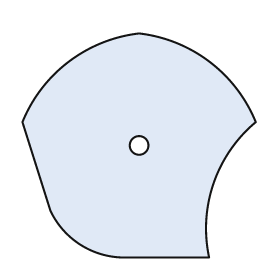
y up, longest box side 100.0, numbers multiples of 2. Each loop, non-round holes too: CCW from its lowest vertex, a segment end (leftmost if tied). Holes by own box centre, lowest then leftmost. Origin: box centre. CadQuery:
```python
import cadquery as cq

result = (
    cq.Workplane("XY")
    .moveTo(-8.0, -48.0)
    .lineTo(30.0, -48.0)
    .threePointArc((32.0, -16.0), (50.0, 10.0))
    .threePointArc((30.0, 36.0), (0.0, 48.0))
    .threePointArc((-30.0, 36.0), (-50.0, 10.0))
    .lineTo(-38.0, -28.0)
    .threePointArc((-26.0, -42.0), (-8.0, -48.0))
    .close()
    .moveTo(0.0, 0.0)
    .circle(4.0)
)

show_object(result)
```